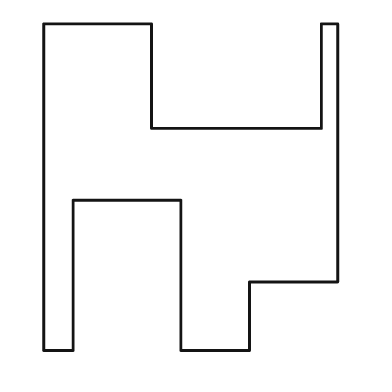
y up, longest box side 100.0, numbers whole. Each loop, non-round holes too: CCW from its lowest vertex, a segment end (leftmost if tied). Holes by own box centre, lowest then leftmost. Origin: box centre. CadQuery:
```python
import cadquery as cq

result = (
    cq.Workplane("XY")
    .moveTo(-45.0, -50.0)
    .lineTo(-36.0, -50.0)
    .lineTo(-36.0, -4.0)
    .lineTo(-3.0, -4.0)
    .lineTo(-3.0, -50.0)
    .lineTo(18.0, -50.0)
    .lineTo(18.0, -29.0)
    .lineTo(45.0, -29.0)
    .lineTo(45.0, 50.0)
    .lineTo(40.0, 50.0)
    .lineTo(40.0, 18.0)
    .lineTo(-12.0, 18.0)
    .lineTo(-12.0, 50.0)
    .lineTo(-45.0, 50.0)
    .close()
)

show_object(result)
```